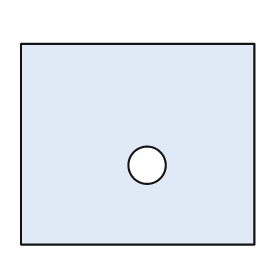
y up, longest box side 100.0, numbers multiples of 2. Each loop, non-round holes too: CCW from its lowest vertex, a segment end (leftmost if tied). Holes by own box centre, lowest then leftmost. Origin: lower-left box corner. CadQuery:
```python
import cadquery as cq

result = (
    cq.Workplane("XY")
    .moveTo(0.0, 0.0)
    .lineTo(100.0, 0.0)
    .lineTo(100.0, 86.0)
    .lineTo(0.0, 86.0)
    .close()
    .moveTo(54.0, 34.0)
    .circle(8.0)
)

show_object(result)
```